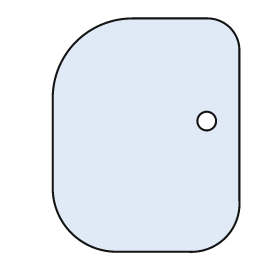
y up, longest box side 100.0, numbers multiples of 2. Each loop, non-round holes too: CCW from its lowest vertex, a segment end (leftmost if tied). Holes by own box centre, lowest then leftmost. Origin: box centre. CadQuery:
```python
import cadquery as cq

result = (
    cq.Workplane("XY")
    .moveTo(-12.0, -50.0)
    .lineTo(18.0, -50.0)
    .threePointArc((34.0, -44.0), (40.0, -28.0))
    .lineTo(40.0, 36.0)
    .threePointArc((36.0, 46.0), (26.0, 50.0))
    .lineTo(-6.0, 50.0)
    .threePointArc((-30.0, 40.0), (-40.0, 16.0))
    .lineTo(-40.0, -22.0)
    .threePointArc((-32.0, -42.0), (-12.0, -50.0))
    .close()
    .moveTo(26.0, 6.0)
    .circle(4.0)
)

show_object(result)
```